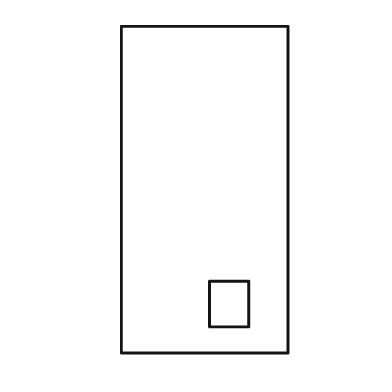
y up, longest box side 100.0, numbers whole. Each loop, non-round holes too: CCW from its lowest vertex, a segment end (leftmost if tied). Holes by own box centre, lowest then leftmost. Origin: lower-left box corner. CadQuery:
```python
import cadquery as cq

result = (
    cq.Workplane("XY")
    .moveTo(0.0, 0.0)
    .lineTo(51.0, 0.0)
    .lineTo(51.0, 100.0)
    .lineTo(0.0, 100.0)
    .close()
    .moveTo(27.0, 8.0)
    .lineTo(39.0, 8.0)
    .lineTo(39.0, 22.0)
    .lineTo(27.0, 22.0)
    .close()
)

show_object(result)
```